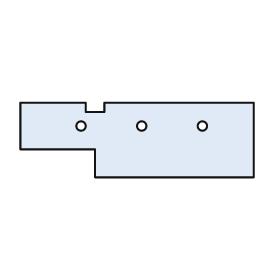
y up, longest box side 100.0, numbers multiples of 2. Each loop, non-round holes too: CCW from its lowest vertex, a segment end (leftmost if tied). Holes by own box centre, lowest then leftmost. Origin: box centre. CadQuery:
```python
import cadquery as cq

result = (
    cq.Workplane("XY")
    .moveTo(-18.0, -16.0)
    .lineTo(50.0, -16.0)
    .lineTo(50.0, 16.0)
    .lineTo(-14.0, 16.0)
    .lineTo(-14.0, 12.0)
    .lineTo(-22.0, 12.0)
    .lineTo(-22.0, 16.0)
    .lineTo(-50.0, 16.0)
    .lineTo(-50.0, -4.0)
    .lineTo(-18.0, -4.0)
    .close()
    .moveTo(-24.0, 6.0)
    .circle(2.0)
    .moveTo(2.0, 6.0)
    .circle(2.0)
    .moveTo(28.0, 6.0)
    .circle(2.0)
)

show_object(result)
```